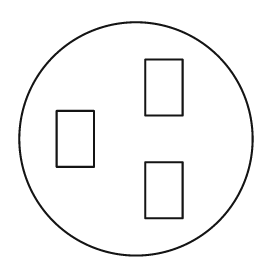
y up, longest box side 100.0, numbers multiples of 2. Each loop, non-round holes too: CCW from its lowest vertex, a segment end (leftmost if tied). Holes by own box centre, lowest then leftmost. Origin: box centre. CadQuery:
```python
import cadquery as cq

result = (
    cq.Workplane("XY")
    .moveTo(0.0, 0.0)
    .circle(50.0)
    .moveTo(4.0, -34.0)
    .lineTo(20.0, -34.0)
    .lineTo(20.0, -10.0)
    .lineTo(4.0, -10.0)
    .close()
    .moveTo(-34.0, -12.0)
    .lineTo(-18.0, -12.0)
    .lineTo(-18.0, 12.0)
    .lineTo(-34.0, 12.0)
    .close()
    .moveTo(4.0, 10.0)
    .lineTo(20.0, 10.0)
    .lineTo(20.0, 34.0)
    .lineTo(4.0, 34.0)
    .close()
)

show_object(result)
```